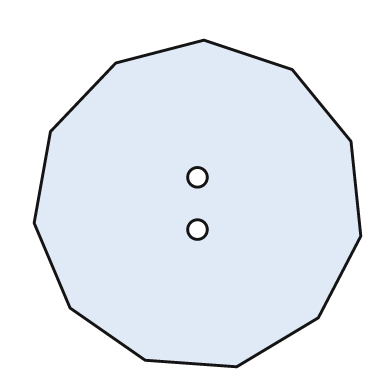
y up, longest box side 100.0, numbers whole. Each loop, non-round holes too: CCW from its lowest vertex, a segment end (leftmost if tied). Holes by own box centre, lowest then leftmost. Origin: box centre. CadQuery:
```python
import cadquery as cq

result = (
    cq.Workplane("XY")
    .moveTo(12.0, -50.0)
    .lineTo(37.0, -35.0)
    .lineTo(50.0, -10.0)
    .lineTo(47.0, 19.0)
    .lineTo(29.0, 41.0)
    .lineTo(2.0, 50.0)
    .lineTo(-25.0, 43.0)
    .lineTo(-45.0, 22.0)
    .lineTo(-50.0, -6.0)
    .lineTo(-39.0, -32.0)
    .lineTo(-16.0, -48.0)
    .close()
    .moveTo(0.0, -8.0)
    .circle(3.0)
    .moveTo(0.0, 8.0)
    .circle(3.0)
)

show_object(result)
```